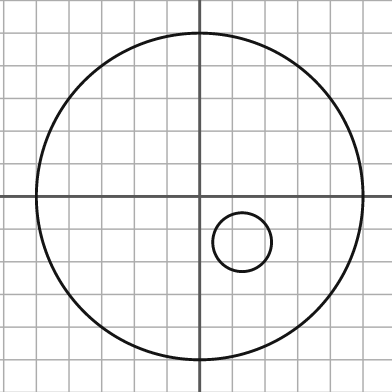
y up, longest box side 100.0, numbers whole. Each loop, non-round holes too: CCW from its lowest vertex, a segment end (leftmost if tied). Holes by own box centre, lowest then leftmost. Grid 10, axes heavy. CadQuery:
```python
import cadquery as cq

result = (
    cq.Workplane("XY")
    .moveTo(0.0, 0.0)
    .circle(50.0)
    .moveTo(13.0, -14.0)
    .circle(9.0)
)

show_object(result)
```